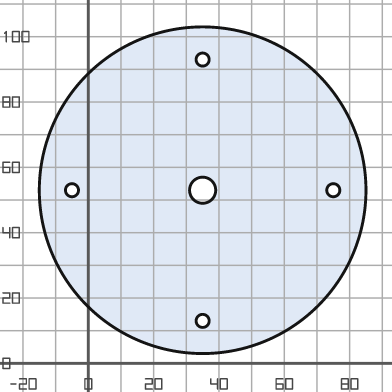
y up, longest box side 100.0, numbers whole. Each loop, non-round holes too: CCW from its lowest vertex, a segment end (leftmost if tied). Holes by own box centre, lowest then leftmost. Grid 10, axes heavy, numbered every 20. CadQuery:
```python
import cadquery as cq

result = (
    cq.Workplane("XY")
    .moveTo(35.0, 53.0)
    .circle(50.0)
    .moveTo(35.0, 13.0)
    .circle(2.0)
    .moveTo(-5.0, 53.0)
    .circle(2.0)
    .moveTo(35.0, 53.0)
    .circle(4.0)
    .moveTo(75.0, 53.0)
    .circle(2.0)
    .moveTo(35.0, 93.0)
    .circle(2.0)
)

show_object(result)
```